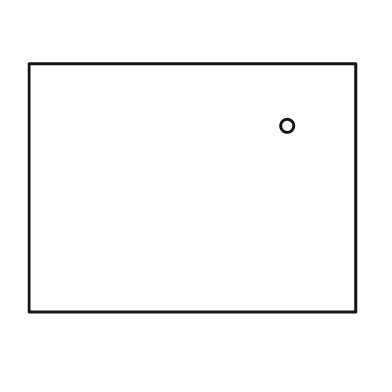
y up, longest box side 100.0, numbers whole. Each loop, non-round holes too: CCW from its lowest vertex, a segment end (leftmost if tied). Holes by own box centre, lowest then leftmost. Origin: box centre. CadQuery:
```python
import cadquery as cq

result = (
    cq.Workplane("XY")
    .moveTo(-50.0, -38.0)
    .lineTo(50.0, -38.0)
    .lineTo(50.0, 38.0)
    .lineTo(-50.0, 38.0)
    .close()
    .moveTo(29.0, 19.0)
    .circle(2.0)
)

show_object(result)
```